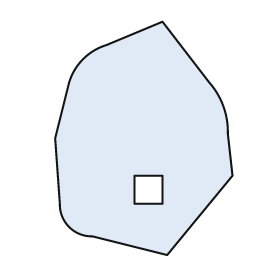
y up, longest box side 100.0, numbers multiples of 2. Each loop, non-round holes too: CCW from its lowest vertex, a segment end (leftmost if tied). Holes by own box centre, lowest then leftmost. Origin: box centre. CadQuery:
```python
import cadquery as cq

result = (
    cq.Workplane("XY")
    .moveTo(10.0, -50.0)
    .lineTo(38.0, -16.0)
    .lineTo(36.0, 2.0)
    .threePointArc((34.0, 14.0), (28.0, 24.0))
    .lineTo(8.0, 50.0)
    .lineTo(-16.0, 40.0)
    .threePointArc((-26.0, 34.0), (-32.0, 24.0))
    .lineTo(-38.0, 0.0)
    .lineTo(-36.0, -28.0)
    .threePointArc((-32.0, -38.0), (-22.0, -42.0))
    .close()
    .moveTo(-4.0, -28.0)
    .lineTo(8.0, -28.0)
    .lineTo(8.0, -16.0)
    .lineTo(-4.0, -16.0)
    .close()
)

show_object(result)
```